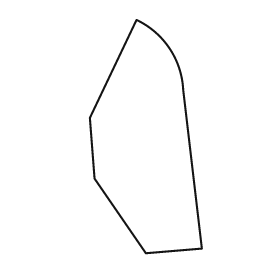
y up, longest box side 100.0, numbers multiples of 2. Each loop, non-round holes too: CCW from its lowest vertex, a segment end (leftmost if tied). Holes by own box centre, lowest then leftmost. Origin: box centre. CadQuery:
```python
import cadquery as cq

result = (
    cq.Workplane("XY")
    .moveTo(0.0, -50.0)
    .lineTo(24.0, -48.0)
    .lineTo(16.0, 20.0)
    .threePointArc((10.0, 38.0), (-4.0, 50.0))
    .lineTo(-24.0, 8.0)
    .lineTo(-22.0, -18.0)
    .close()
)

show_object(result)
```